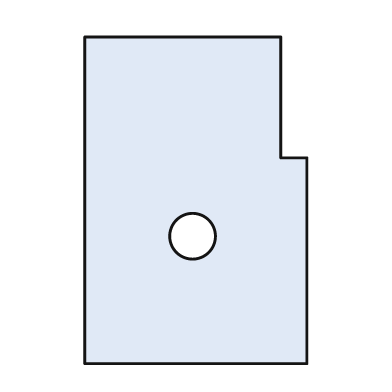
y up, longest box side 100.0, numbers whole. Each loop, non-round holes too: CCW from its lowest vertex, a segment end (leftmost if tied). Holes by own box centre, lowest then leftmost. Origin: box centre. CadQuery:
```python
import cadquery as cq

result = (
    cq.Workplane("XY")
    .moveTo(-34.0, -50.0)
    .lineTo(34.0, -50.0)
    .lineTo(34.0, 13.0)
    .lineTo(26.0, 13.0)
    .lineTo(26.0, 50.0)
    .lineTo(-34.0, 50.0)
    .close()
    .moveTo(-1.0, -11.0)
    .circle(7.0)
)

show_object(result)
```